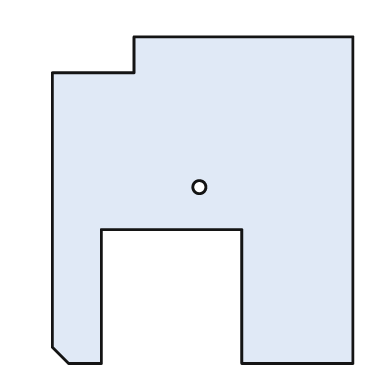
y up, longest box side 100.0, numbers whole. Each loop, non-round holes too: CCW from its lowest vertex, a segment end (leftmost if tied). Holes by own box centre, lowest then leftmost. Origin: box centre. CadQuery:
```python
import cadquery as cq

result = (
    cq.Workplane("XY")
    .moveTo(-41.0, -50.0)
    .lineTo(-31.0, -50.0)
    .lineTo(-31.0, -9.0)
    .lineTo(12.0, -9.0)
    .lineTo(12.0, -50.0)
    .lineTo(46.0, -50.0)
    .lineTo(46.0, 50.0)
    .lineTo(-21.0, 50.0)
    .lineTo(-21.0, 39.0)
    .lineTo(-46.0, 39.0)
    .lineTo(-46.0, -45.0)
    .close()
    .moveTo(-1.0, 4.0)
    .circle(2.0)
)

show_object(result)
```